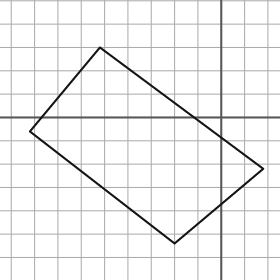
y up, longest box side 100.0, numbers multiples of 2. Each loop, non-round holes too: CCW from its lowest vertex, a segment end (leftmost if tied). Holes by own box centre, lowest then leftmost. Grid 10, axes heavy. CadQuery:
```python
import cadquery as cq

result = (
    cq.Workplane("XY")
    .moveTo(-20.0, -54.0)
    .lineTo(18.0, -22.0)
    .lineTo(-52.0, 30.0)
    .lineTo(-82.0, -6.0)
    .close()
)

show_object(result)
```